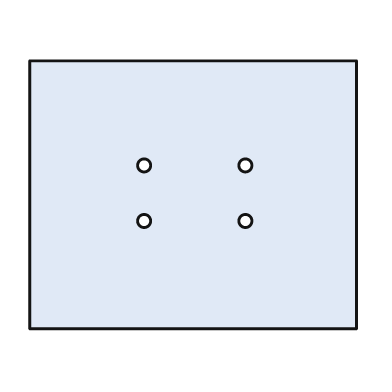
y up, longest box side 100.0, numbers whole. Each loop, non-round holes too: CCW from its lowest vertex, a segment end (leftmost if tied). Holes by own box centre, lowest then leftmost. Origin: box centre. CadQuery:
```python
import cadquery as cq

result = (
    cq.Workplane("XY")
    .moveTo(-50.0, -41.0)
    .lineTo(50.0, -41.0)
    .lineTo(50.0, 41.0)
    .lineTo(-50.0, 41.0)
    .close()
    .moveTo(-15.0, -8.0)
    .circle(2.0)
    .moveTo(16.0, -8.0)
    .circle(2.0)
    .moveTo(-15.0, 9.0)
    .circle(2.0)
    .moveTo(16.0, 9.0)
    .circle(2.0)
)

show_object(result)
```